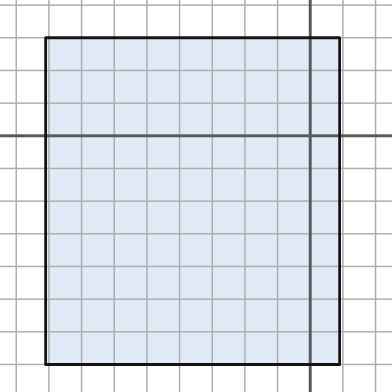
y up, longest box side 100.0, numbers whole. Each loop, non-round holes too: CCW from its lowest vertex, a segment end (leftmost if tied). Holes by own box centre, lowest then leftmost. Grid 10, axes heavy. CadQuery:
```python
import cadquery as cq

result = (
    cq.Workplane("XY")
    .moveTo(-81.0, -70.0)
    .lineTo(9.0, -70.0)
    .lineTo(9.0, 30.0)
    .lineTo(-81.0, 30.0)
    .close()
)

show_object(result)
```